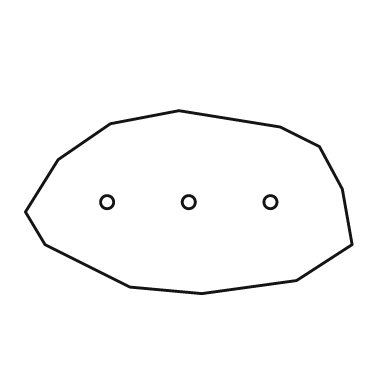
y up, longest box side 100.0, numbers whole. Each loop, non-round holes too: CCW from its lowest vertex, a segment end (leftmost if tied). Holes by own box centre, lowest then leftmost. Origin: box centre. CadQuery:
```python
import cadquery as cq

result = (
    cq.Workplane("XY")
    .moveTo(4.0, -28.0)
    .lineTo(33.0, -24.0)
    .lineTo(50.0, -13.0)
    .lineTo(47.0, 4.0)
    .lineTo(40.0, 17.0)
    .lineTo(28.0, 23.0)
    .lineTo(-3.0, 28.0)
    .lineTo(-24.0, 24.0)
    .lineTo(-40.0, 13.0)
    .lineTo(-50.0, -3.0)
    .lineTo(-44.0, -13.0)
    .lineTo(-18.0, -26.0)
    .close()
    .moveTo(-25.0, 0.0)
    .circle(2.0)
    .moveTo(0.0, 0.0)
    .circle(2.0)
    .moveTo(25.0, 0.0)
    .circle(2.0)
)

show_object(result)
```